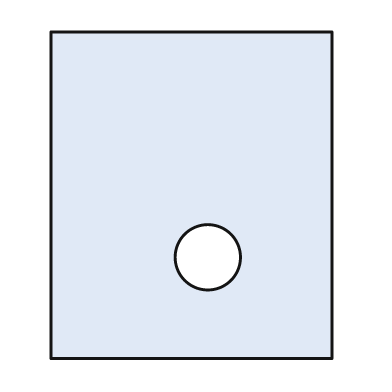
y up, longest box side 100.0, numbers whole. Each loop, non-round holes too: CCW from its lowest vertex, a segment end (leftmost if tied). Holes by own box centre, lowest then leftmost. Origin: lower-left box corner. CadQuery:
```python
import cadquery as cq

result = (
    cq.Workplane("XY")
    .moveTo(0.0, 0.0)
    .lineTo(86.0, 0.0)
    .lineTo(86.0, 100.0)
    .lineTo(0.0, 100.0)
    .close()
    .moveTo(48.0, 31.0)
    .circle(10.0)
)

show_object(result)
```